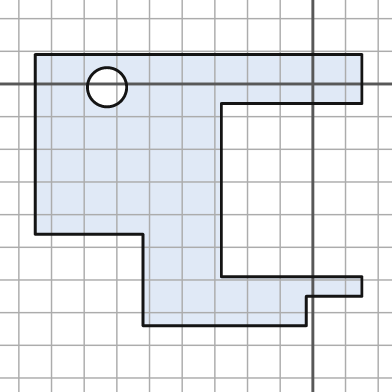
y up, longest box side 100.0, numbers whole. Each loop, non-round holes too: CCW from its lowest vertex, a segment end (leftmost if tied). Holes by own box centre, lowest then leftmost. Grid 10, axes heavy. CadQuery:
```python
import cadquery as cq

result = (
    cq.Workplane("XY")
    .moveTo(-52.0, -74.0)
    .lineTo(-2.0, -74.0)
    .lineTo(-2.0, -65.0)
    .lineTo(15.0, -65.0)
    .lineTo(15.0, -59.0)
    .lineTo(-28.0, -59.0)
    .lineTo(-28.0, -6.0)
    .lineTo(15.0, -6.0)
    .lineTo(15.0, 9.0)
    .lineTo(-85.0, 9.0)
    .lineTo(-85.0, -46.0)
    .lineTo(-52.0, -46.0)
    .close()
    .moveTo(-63.0, -1.0)
    .circle(6.0)
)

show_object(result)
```